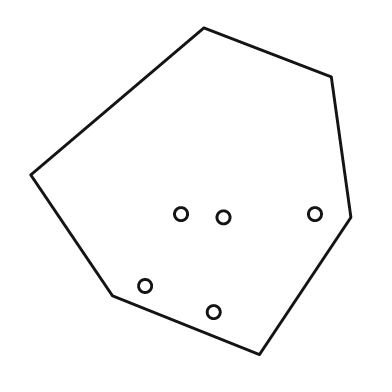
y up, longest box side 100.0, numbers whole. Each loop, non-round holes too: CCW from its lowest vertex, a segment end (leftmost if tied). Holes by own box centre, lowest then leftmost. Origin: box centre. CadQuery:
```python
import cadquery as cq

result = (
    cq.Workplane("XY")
    .moveTo(21.0, -50.0)
    .lineTo(49.0, -8.0)
    .lineTo(43.0, 35.0)
    .lineTo(4.0, 50.0)
    .lineTo(-49.0, 5.0)
    .lineTo(-24.0, -32.0)
    .close()
    .moveTo(7.0, -37.0)
    .circle(2.0)
    .moveTo(-14.0, -29.0)
    .circle(2.0)
    .moveTo(10.0, -8.0)
    .circle(2.0)
    .moveTo(-3.0, -7.0)
    .circle(2.0)
    .moveTo(38.0, -7.0)
    .circle(2.0)
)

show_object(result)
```